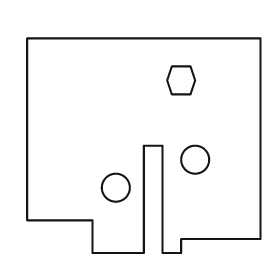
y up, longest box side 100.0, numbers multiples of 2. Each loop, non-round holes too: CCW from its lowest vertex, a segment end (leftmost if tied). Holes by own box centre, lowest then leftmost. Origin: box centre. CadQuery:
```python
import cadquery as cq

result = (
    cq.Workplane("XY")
    .moveTo(-22.0, -46.0)
    .lineTo(0.0, -46.0)
    .lineTo(0.0, 0.0)
    .lineTo(8.0, 0.0)
    .lineTo(8.0, -46.0)
    .lineTo(16.0, -46.0)
    .lineTo(16.0, -40.0)
    .lineTo(50.0, -40.0)
    .lineTo(50.0, 46.0)
    .lineTo(-50.0, 46.0)
    .lineTo(-50.0, -32.0)
    .lineTo(-22.0, -32.0)
    .close()
    .moveTo(-12.0, -18.0)
    .circle(6.0)
    .moveTo(22.0, -6.0)
    .circle(6.0)
    .moveTo(12.0, 22.0)
    .lineTo(20.0, 22.0)
    .lineTo(22.0, 28.0)
    .lineTo(20.0, 34.0)
    .lineTo(12.0, 34.0)
    .lineTo(10.0, 28.0)
    .close()
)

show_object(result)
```